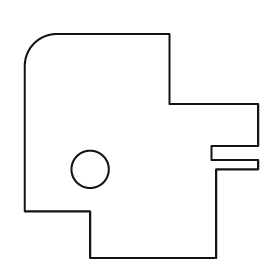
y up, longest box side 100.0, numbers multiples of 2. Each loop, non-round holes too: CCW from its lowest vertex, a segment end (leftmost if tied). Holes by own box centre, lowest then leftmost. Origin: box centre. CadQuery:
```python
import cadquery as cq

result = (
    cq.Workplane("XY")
    .moveTo(-22.0, -48.0)
    .lineTo(32.0, -48.0)
    .lineTo(32.0, -10.0)
    .lineTo(50.0, -10.0)
    .lineTo(50.0, -6.0)
    .lineTo(30.0, -6.0)
    .lineTo(30.0, 0.0)
    .lineTo(50.0, 0.0)
    .lineTo(50.0, 18.0)
    .lineTo(12.0, 18.0)
    .lineTo(12.0, 48.0)
    .lineTo(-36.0, 48.0)
    .threePointArc((-46.0, 44.0), (-50.0, 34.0))
    .lineTo(-50.0, -28.0)
    .lineTo(-22.0, -28.0)
    .close()
    .moveTo(-22.0, -10.0)
    .circle(8.0)
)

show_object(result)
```